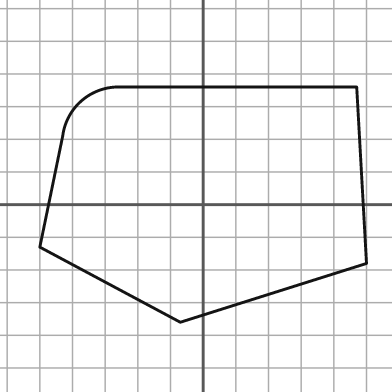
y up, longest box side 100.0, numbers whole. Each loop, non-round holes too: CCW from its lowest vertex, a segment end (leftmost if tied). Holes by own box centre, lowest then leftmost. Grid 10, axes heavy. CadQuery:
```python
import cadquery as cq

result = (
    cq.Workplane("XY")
    .moveTo(-7.0, -36.0)
    .lineTo(50.0, -18.0)
    .lineTo(47.0, 36.0)
    .lineTo(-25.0, 36.0)
    .threePointArc((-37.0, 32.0), (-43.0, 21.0))
    .lineTo(-50.0, -13.0)
    .close()
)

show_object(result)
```